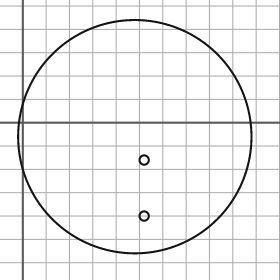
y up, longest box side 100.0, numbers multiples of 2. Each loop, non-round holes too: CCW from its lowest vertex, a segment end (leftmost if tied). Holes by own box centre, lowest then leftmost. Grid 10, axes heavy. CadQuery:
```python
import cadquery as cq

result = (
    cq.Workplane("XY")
    .moveTo(48.0, -6.0)
    .circle(50.0)
    .moveTo(52.0, -40.0)
    .circle(2.0)
    .moveTo(52.0, -16.0)
    .circle(2.0)
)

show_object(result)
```